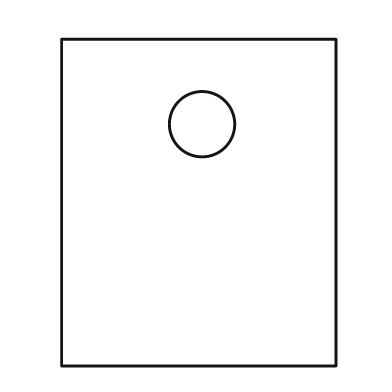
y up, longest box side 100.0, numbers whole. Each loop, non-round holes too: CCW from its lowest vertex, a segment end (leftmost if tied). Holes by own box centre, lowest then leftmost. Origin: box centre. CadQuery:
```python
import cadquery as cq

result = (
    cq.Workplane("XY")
    .moveTo(-42.0, -50.0)
    .lineTo(42.0, -50.0)
    .lineTo(42.0, 50.0)
    .lineTo(-42.0, 50.0)
    .close()
    .moveTo(1.0, 24.0)
    .circle(10.0)
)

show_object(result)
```